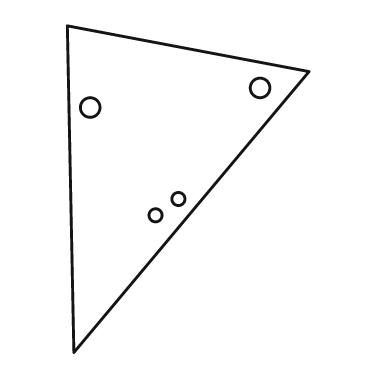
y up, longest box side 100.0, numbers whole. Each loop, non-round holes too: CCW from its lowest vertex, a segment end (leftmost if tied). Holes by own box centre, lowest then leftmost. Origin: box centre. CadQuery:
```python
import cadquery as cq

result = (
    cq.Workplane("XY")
    .moveTo(-35.0, -50.0)
    .lineTo(37.0, 36.0)
    .lineTo(-37.0, 50.0)
    .close()
    .moveTo(-10.0, -8.0)
    .circle(2.0)
    .moveTo(-3.0, -3.0)
    .circle(2.0)
    .moveTo(-30.0, 25.0)
    .circle(3.0)
    .moveTo(22.0, 31.0)
    .circle(3.0)
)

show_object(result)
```